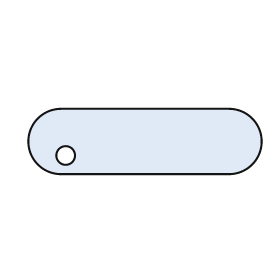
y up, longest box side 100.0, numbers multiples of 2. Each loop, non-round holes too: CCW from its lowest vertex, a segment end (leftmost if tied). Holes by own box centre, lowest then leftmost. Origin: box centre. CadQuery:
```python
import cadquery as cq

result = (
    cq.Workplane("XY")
    .moveTo(-36.0, -14.0)
    .lineTo(36.0, -14.0)
    .threePointArc((50.0, 0.0), (36.0, 14.0))
    .lineTo(-36.0, 14.0)
    .threePointArc((-50.0, 0.0), (-36.0, -14.0))
    .close()
    .moveTo(-34.0, -6.0)
    .circle(4.0)
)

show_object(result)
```